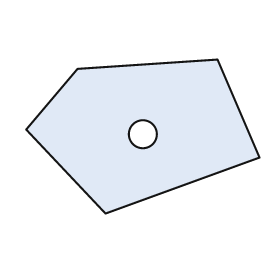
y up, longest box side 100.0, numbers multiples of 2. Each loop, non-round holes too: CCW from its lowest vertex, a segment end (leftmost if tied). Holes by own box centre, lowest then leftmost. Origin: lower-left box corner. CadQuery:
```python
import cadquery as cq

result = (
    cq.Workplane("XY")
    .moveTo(34.0, 0.0)
    .lineTo(100.0, 24.0)
    .lineTo(82.0, 66.0)
    .lineTo(22.0, 62.0)
    .lineTo(0.0, 36.0)
    .close()
    .moveTo(50.0, 34.0)
    .circle(6.0)
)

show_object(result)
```